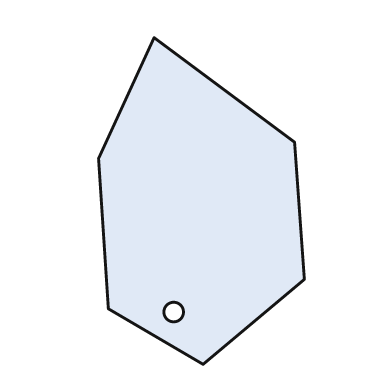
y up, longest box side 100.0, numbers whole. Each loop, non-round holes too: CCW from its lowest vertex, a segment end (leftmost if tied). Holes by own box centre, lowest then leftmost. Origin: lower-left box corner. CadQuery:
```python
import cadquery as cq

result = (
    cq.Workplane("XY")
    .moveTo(32.0, 0.0)
    .lineTo(63.0, 26.0)
    .lineTo(60.0, 68.0)
    .lineTo(17.0, 100.0)
    .lineTo(0.0, 63.0)
    .lineTo(3.0, 17.0)
    .close()
    .moveTo(23.0, 16.0)
    .circle(3.0)
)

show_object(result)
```